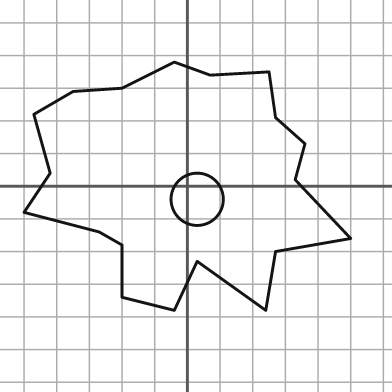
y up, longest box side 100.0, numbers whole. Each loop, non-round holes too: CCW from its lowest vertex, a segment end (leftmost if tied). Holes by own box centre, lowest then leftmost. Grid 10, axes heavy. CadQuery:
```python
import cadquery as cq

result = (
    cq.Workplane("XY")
    .moveTo(-4.0, -38.0)
    .lineTo(3.0, -23.0)
    .lineTo(24.0, -38.0)
    .lineTo(27.0, -20.0)
    .lineTo(50.0, -16.0)
    .lineTo(33.0, 2.0)
    .lineTo(36.0, 13.0)
    .lineTo(27.0, 21.0)
    .lineTo(25.0, 35.0)
    .lineTo(7.0, 34.0)
    .lineTo(-4.0, 38.0)
    .lineTo(-20.0, 30.0)
    .lineTo(-35.0, 29.0)
    .lineTo(-47.0, 22.0)
    .lineTo(-42.0, 4.0)
    .lineTo(-50.0, -8.0)
    .lineTo(-27.0, -14.0)
    .lineTo(-20.0, -18.0)
    .lineTo(-20.0, -34.0)
    .close()
    .moveTo(3.0, -4.0)
    .circle(8.0)
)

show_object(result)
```